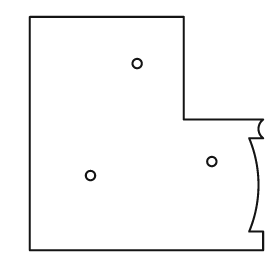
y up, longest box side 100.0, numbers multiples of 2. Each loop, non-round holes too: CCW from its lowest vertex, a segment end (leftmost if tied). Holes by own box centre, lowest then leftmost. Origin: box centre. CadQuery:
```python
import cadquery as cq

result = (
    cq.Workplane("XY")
    .moveTo(-50.0, -50.0)
    .lineTo(50.0, -50.0)
    .lineTo(50.0, -42.0)
    .lineTo(44.0, -42.0)
    .threePointArc((48.0, -22.0), (44.0, -2.0))
    .lineTo(50.0, -2.0)
    .threePointArc((48.0, 2.0), (50.0, 6.0))
    .lineTo(16.0, 6.0)
    .lineTo(16.0, 50.0)
    .lineTo(-50.0, 50.0)
    .close()
    .moveTo(-24.0, -18.0)
    .circle(2.0)
    .moveTo(28.0, -12.0)
    .circle(2.0)
    .moveTo(-4.0, 30.0)
    .circle(2.0)
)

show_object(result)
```